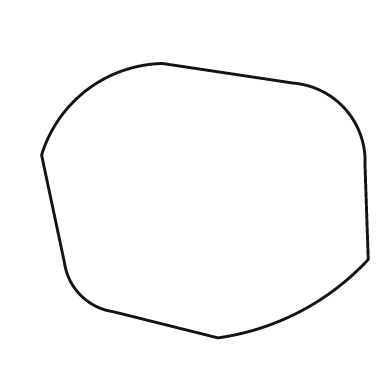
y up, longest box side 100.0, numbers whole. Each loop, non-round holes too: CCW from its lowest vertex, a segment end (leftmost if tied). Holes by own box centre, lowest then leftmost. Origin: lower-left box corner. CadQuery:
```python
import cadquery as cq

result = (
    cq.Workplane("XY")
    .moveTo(54.0, 0.0)
    .threePointArc((79.0, 8.0), (100.0, 24.0))
    .lineTo(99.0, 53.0)
    .threePointArc((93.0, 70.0), (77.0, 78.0))
    .lineTo(37.0, 84.0)
    .threePointArc((14.0, 76.0), (0.0, 56.0))
    .lineTo(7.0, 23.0)
    .threePointArc((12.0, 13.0), (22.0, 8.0))
    .close()
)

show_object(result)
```